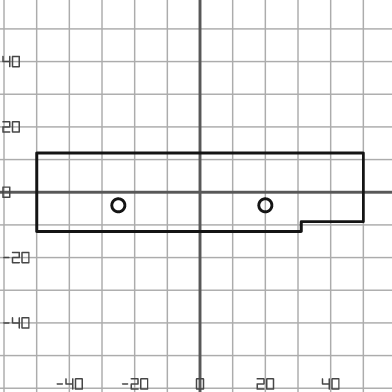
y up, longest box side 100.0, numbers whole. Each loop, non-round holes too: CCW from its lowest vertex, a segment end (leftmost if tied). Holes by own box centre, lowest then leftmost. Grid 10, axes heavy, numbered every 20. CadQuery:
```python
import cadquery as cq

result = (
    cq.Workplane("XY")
    .moveTo(-50.0, -12.0)
    .lineTo(31.0, -12.0)
    .lineTo(31.0, -9.0)
    .lineTo(50.0, -9.0)
    .lineTo(50.0, 12.0)
    .lineTo(-50.0, 12.0)
    .close()
    .moveTo(-25.0, -4.0)
    .circle(2.0)
    .moveTo(20.0, -4.0)
    .circle(2.0)
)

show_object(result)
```